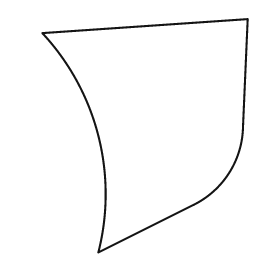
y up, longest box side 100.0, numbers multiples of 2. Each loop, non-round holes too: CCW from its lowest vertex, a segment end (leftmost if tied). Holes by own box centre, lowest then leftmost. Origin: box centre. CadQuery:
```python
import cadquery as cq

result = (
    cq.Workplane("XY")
    .moveTo(-20.0, -50.0)
    .lineTo(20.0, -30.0)
    .threePointArc((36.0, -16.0), (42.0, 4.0))
    .lineTo(44.0, 50.0)
    .lineTo(-44.0, 44.0)
    .threePointArc((-20.0, 0.0), (-20.0, -50.0))
    .close()
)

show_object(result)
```